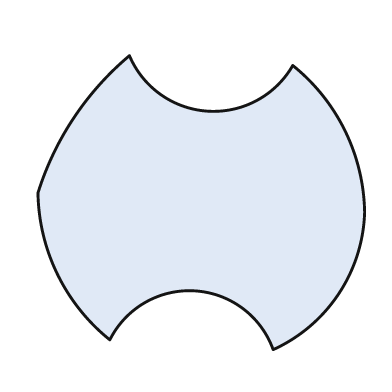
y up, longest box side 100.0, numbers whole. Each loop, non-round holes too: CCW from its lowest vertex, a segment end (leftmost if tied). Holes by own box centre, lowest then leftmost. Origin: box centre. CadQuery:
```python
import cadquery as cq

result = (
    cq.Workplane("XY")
    .moveTo(22.0, -45.0)
    .threePointArc((42.0, -28.0), (50.0, -3.0))
    .threePointArc((44.0, 22.0), (28.0, 42.0))
    .threePointArc((2.0, 28.0), (-22.0, 45.0))
    .threePointArc((-39.0, 26.0), (-50.0, 3.0))
    .threePointArc((-44.0, -22.0), (-28.0, -42.0))
    .threePointArc((-2.0, -27.0), (22.0, -45.0))
    .close()
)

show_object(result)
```